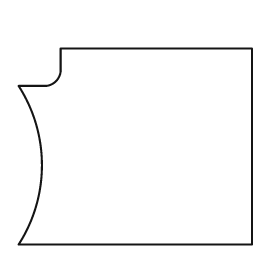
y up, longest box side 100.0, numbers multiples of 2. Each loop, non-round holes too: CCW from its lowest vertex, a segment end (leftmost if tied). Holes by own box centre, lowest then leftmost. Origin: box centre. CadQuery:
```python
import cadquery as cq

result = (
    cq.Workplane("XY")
    .moveTo(-50.0, -42.0)
    .lineTo(50.0, -42.0)
    .lineTo(50.0, 42.0)
    .lineTo(-32.0, 42.0)
    .lineTo(-32.0, 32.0)
    .threePointArc((-34.0, 28.0), (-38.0, 26.0))
    .lineTo(-50.0, 26.0)
    .threePointArc((-40.0, -8.0), (-50.0, -42.0))
    .close()
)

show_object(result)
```